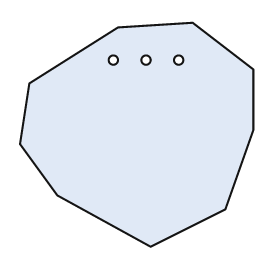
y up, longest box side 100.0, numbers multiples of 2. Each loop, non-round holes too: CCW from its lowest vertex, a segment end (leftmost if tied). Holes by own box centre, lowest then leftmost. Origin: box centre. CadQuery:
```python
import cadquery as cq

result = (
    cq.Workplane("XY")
    .moveTo(6.0, -48.0)
    .lineTo(38.0, -32.0)
    .lineTo(50.0, 2.0)
    .lineTo(50.0, 28.0)
    .lineTo(24.0, 48.0)
    .lineTo(-8.0, 46.0)
    .lineTo(-46.0, 22.0)
    .lineTo(-50.0, -4.0)
    .lineTo(-34.0, -26.0)
    .close()
    .moveTo(-10.0, 32.0)
    .circle(2.0)
    .moveTo(4.0, 32.0)
    .circle(2.0)
    .moveTo(18.0, 32.0)
    .circle(2.0)
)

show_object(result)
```